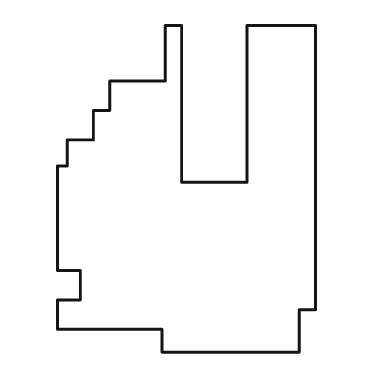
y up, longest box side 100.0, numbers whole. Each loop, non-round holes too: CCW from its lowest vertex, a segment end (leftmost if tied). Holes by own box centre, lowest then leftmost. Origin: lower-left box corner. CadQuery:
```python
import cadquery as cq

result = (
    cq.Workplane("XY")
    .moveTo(32.0, 0.0)
    .lineTo(74.0, 0.0)
    .lineTo(74.0, 13.0)
    .lineTo(79.0, 13.0)
    .lineTo(79.0, 100.0)
    .lineTo(58.0, 100.0)
    .lineTo(58.0, 52.0)
    .lineTo(38.0, 52.0)
    .lineTo(38.0, 100.0)
    .lineTo(33.0, 100.0)
    .lineTo(33.0, 83.0)
    .lineTo(16.0, 83.0)
    .lineTo(16.0, 74.0)
    .lineTo(11.0, 74.0)
    .lineTo(11.0, 65.0)
    .lineTo(3.0, 65.0)
    .lineTo(3.0, 57.0)
    .lineTo(0.0, 57.0)
    .lineTo(0.0, 25.0)
    .lineTo(7.0, 25.0)
    .lineTo(7.0, 16.0)
    .lineTo(0.0, 16.0)
    .lineTo(0.0, 7.0)
    .lineTo(32.0, 7.0)
    .close()
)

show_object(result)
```